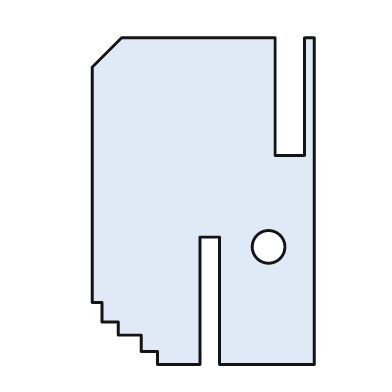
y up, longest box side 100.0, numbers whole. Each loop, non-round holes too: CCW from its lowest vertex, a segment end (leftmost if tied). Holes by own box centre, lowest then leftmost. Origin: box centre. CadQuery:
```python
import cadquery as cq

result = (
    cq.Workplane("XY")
    .moveTo(-14.0, -50.0)
    .lineTo(-1.0, -50.0)
    .lineTo(-1.0, -11.0)
    .lineTo(5.0, -11.0)
    .lineTo(5.0, -50.0)
    .lineTo(34.0, -50.0)
    .lineTo(34.0, 50.0)
    .lineTo(31.0, 50.0)
    .lineTo(31.0, 14.0)
    .lineTo(22.0, 14.0)
    .lineTo(22.0, 50.0)
    .lineTo(-25.0, 50.0)
    .lineTo(-34.0, 41.0)
    .lineTo(-34.0, -31.0)
    .lineTo(-31.0, -31.0)
    .lineTo(-31.0, -37.0)
    .lineTo(-26.0, -37.0)
    .lineTo(-26.0, -41.0)
    .lineTo(-19.0, -41.0)
    .lineTo(-19.0, -46.0)
    .lineTo(-14.0, -46.0)
    .close()
    .moveTo(20.0, -14.0)
    .circle(5.0)
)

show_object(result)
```